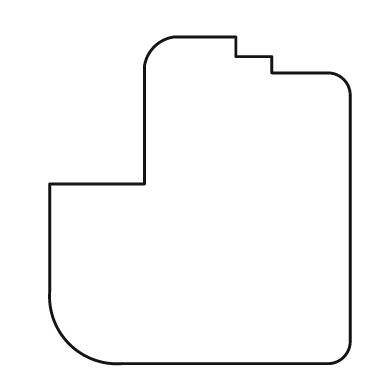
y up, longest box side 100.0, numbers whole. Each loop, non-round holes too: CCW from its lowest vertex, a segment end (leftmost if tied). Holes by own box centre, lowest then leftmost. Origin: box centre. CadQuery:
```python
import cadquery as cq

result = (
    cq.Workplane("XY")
    .moveTo(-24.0, -50.0)
    .lineTo(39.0, -50.0)
    .threePointArc((44.0, -48.0), (46.0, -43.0))
    .lineTo(46.0, 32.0)
    .threePointArc((44.0, 37.0), (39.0, 39.0))
    .lineTo(22.0, 39.0)
    .lineTo(22.0, 44.0)
    .lineTo(11.0, 44.0)
    .lineTo(11.0, 50.0)
    .lineTo(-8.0, 50.0)
    .threePointArc((-14.0, 47.0), (-17.0, 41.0))
    .lineTo(-17.0, 5.0)
    .lineTo(-46.0, 5.0)
    .lineTo(-46.0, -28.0)
    .threePointArc((-40.0, -44.0), (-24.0, -50.0))
    .close()
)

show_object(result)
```